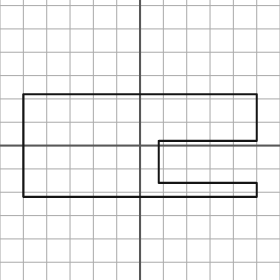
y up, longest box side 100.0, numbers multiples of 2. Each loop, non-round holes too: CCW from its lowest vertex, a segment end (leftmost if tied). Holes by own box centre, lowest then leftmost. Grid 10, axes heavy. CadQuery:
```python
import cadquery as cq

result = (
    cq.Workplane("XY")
    .moveTo(-50.0, -22.0)
    .lineTo(50.0, -22.0)
    .lineTo(50.0, -16.0)
    .lineTo(8.0, -16.0)
    .lineTo(8.0, 2.0)
    .lineTo(50.0, 2.0)
    .lineTo(50.0, 22.0)
    .lineTo(-50.0, 22.0)
    .close()
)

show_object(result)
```